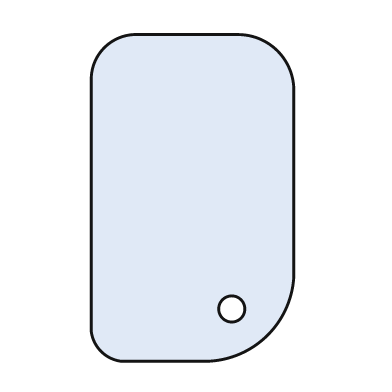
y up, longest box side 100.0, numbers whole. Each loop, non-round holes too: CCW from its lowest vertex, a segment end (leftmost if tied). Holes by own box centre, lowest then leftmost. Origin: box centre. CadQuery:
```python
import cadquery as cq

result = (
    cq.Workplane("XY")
    .moveTo(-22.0, -50.0)
    .lineTo(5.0, -50.0)
    .threePointArc((23.0, -42.0), (31.0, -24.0))
    .lineTo(31.0, 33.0)
    .threePointArc((26.0, 45.0), (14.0, 50.0))
    .lineTo(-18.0, 50.0)
    .threePointArc((-27.0, 46.0), (-31.0, 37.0))
    .lineTo(-31.0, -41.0)
    .threePointArc((-28.0, -47.0), (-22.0, -50.0))
    .close()
    .moveTo(12.0, -34.0)
    .circle(4.0)
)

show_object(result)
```